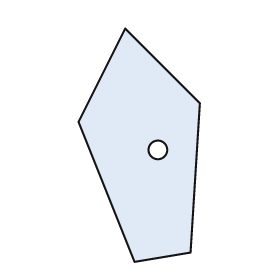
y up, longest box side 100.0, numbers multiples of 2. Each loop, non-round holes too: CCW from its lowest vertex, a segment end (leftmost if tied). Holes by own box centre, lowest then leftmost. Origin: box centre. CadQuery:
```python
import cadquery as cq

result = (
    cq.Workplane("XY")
    .moveTo(-2.0, -50.0)
    .lineTo(22.0, -46.0)
    .lineTo(26.0, 18.0)
    .lineTo(-6.0, 50.0)
    .lineTo(-26.0, 10.0)
    .close()
    .moveTo(8.0, -2.0)
    .circle(4.0)
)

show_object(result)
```